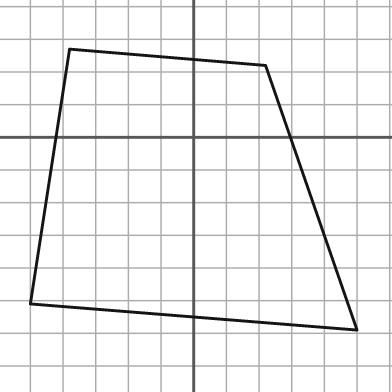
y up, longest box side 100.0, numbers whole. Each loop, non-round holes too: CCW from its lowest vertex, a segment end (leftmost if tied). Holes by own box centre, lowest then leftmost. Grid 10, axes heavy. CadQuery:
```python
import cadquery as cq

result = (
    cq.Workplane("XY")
    .moveTo(50.0, -59.0)
    .lineTo(22.0, 22.0)
    .lineTo(-38.0, 27.0)
    .lineTo(-50.0, -51.0)
    .close()
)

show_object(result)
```